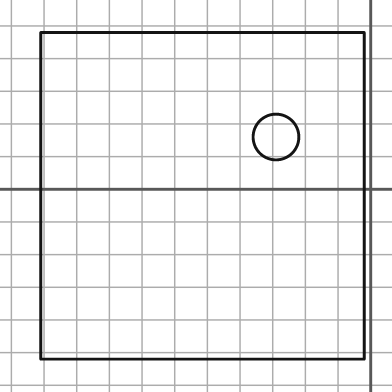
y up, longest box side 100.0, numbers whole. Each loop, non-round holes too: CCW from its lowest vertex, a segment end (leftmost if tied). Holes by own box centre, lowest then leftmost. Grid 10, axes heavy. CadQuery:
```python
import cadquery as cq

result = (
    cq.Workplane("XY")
    .moveTo(-101.0, -52.0)
    .lineTo(-2.0, -52.0)
    .lineTo(-2.0, 48.0)
    .lineTo(-101.0, 48.0)
    .close()
    .moveTo(-29.0, 16.0)
    .circle(7.0)
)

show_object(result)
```